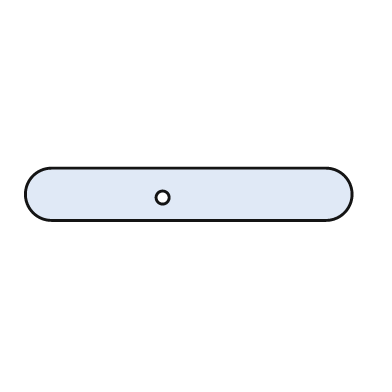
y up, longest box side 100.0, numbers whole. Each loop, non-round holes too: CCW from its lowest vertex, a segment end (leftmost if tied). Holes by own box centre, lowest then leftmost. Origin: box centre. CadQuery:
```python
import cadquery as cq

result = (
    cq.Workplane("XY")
    .moveTo(-42.0, -8.0)
    .lineTo(42.0, -8.0)
    .threePointArc((50.0, 0.0), (42.0, 8.0))
    .lineTo(-42.0, 8.0)
    .threePointArc((-50.0, 0.0), (-42.0, -8.0))
    .close()
    .moveTo(-8.0, -1.0)
    .circle(2.0)
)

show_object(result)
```